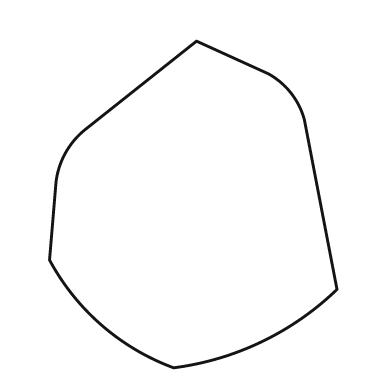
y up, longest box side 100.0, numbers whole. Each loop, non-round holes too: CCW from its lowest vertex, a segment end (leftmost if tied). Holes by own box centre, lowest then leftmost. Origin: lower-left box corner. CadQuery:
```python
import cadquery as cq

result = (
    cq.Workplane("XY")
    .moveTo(38.0, 0.0)
    .threePointArc((65.0, 8.0), (88.0, 24.0))
    .lineTo(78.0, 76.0)
    .threePointArc((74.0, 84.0), (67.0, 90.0))
    .lineTo(45.0, 100.0)
    .lineTo(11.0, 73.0)
    .threePointArc((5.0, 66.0), (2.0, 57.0))
    .lineTo(0.0, 33.0)
    .threePointArc((16.0, 13.0), (38.0, 0.0))
    .close()
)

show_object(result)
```